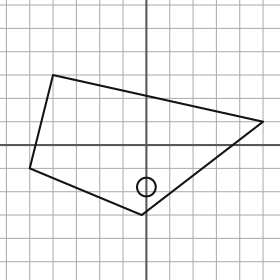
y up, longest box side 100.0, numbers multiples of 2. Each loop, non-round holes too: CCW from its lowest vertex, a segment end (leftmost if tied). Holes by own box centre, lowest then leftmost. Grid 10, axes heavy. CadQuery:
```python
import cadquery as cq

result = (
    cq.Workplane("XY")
    .moveTo(-2.0, -30.0)
    .lineTo(50.0, 10.0)
    .lineTo(-40.0, 30.0)
    .lineTo(-50.0, -10.0)
    .close()
    .moveTo(0.0, -18.0)
    .circle(4.0)
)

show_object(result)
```